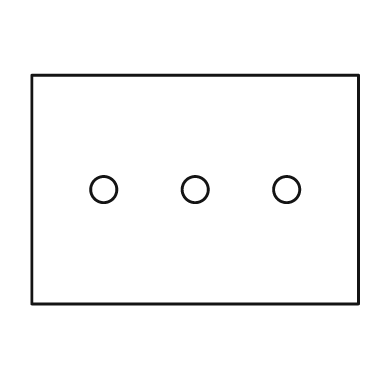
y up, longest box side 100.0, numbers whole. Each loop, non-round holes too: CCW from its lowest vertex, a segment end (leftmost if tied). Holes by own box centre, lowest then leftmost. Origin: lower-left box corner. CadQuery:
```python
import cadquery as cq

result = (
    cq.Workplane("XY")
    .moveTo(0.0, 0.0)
    .lineTo(100.0, 0.0)
    .lineTo(100.0, 70.0)
    .lineTo(0.0, 70.0)
    .close()
    .moveTo(22.0, 35.0)
    .circle(4.0)
    .moveTo(50.0, 35.0)
    .circle(4.0)
    .moveTo(78.0, 35.0)
    .circle(4.0)
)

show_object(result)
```